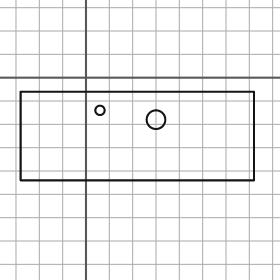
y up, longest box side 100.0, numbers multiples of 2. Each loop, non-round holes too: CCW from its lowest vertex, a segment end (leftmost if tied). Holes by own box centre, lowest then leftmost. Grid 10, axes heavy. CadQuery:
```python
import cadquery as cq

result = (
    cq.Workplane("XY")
    .moveTo(-28.0, -44.0)
    .lineTo(72.0, -44.0)
    .lineTo(72.0, -6.0)
    .lineTo(-28.0, -6.0)
    .close()
    .moveTo(30.0, -18.0)
    .circle(4.0)
    .moveTo(6.0, -14.0)
    .circle(2.0)
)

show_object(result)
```